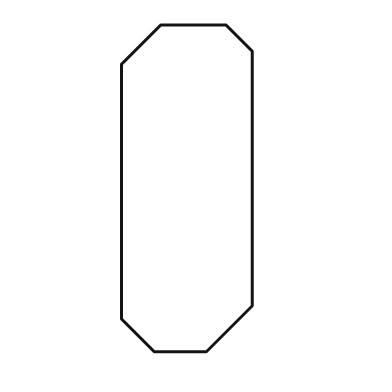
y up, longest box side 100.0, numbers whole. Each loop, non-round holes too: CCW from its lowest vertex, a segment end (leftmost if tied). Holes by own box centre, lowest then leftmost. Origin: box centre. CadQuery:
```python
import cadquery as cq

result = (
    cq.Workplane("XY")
    .moveTo(-10.0, -50.0)
    .lineTo(6.0, -50.0)
    .lineTo(20.0, -36.0)
    .lineTo(20.0, 42.0)
    .lineTo(12.0, 50.0)
    .lineTo(-8.0, 50.0)
    .lineTo(-20.0, 38.0)
    .lineTo(-20.0, -40.0)
    .close()
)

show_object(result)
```